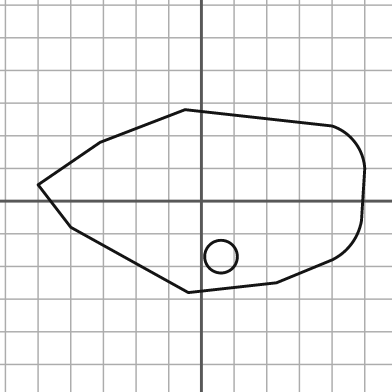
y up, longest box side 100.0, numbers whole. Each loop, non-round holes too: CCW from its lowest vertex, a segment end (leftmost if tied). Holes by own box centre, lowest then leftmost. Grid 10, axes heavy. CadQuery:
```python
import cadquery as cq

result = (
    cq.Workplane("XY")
    .moveTo(-4.0, -28.0)
    .lineTo(23.0, -25.0)
    .lineTo(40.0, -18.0)
    .threePointArc((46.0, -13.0), (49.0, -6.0))
    .lineTo(50.0, 10.0)
    .threePointArc((47.0, 18.0), (40.0, 23.0))
    .lineTo(-5.0, 28.0)
    .lineTo(-31.0, 18.0)
    .lineTo(-50.0, 5.0)
    .lineTo(-40.0, -8.0)
    .close()
    .moveTo(6.0, -17.0)
    .circle(5.0)
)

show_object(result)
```